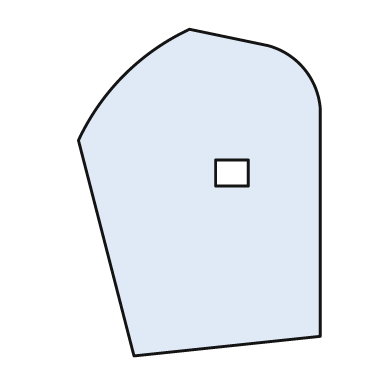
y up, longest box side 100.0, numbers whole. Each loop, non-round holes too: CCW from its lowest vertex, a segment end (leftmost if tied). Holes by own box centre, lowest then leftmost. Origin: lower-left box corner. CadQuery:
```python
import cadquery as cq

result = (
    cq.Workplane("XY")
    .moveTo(17.0, 0.0)
    .lineTo(74.0, 6.0)
    .lineTo(74.0, 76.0)
    .threePointArc((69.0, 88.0), (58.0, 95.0))
    .lineTo(34.0, 100.0)
    .threePointArc((14.0, 86.0), (0.0, 66.0))
    .close()
    .moveTo(42.0, 52.0)
    .lineTo(52.0, 52.0)
    .lineTo(52.0, 60.0)
    .lineTo(42.0, 60.0)
    .close()
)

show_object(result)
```